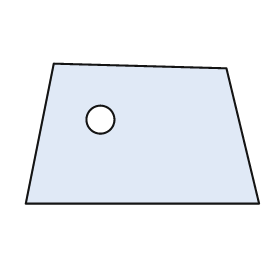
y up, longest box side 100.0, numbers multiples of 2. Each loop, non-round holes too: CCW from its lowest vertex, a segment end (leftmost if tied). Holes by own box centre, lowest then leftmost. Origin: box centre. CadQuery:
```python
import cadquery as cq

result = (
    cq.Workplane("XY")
    .moveTo(-50.0, -30.0)
    .lineTo(50.0, -30.0)
    .lineTo(36.0, 28.0)
    .lineTo(-38.0, 30.0)
    .close()
    .moveTo(-18.0, 6.0)
    .circle(6.0)
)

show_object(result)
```